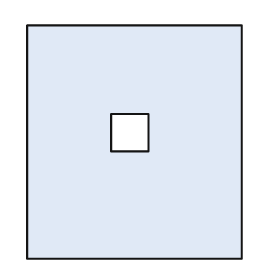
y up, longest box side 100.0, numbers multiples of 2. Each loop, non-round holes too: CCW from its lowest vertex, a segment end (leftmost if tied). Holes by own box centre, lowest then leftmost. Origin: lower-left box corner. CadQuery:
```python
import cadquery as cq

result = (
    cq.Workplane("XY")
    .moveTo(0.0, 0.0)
    .lineTo(92.0, 0.0)
    .lineTo(92.0, 100.0)
    .lineTo(0.0, 100.0)
    .close()
    .moveTo(36.0, 46.0)
    .lineTo(52.0, 46.0)
    .lineTo(52.0, 62.0)
    .lineTo(36.0, 62.0)
    .close()
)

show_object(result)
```